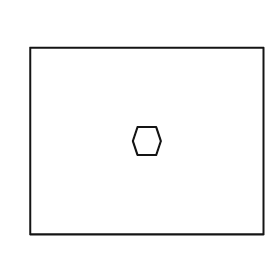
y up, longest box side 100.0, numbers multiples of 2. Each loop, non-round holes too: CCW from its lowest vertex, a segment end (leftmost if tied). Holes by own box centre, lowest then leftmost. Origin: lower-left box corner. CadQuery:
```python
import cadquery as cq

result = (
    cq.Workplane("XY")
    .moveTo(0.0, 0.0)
    .lineTo(100.0, 0.0)
    .lineTo(100.0, 80.0)
    .lineTo(0.0, 80.0)
    .close()
    .moveTo(46.0, 34.0)
    .lineTo(54.0, 34.0)
    .lineTo(56.0, 40.0)
    .lineTo(54.0, 46.0)
    .lineTo(46.0, 46.0)
    .lineTo(44.0, 40.0)
    .close()
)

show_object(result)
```